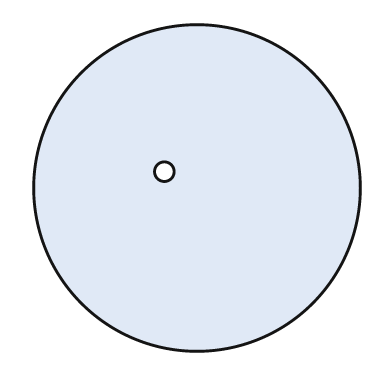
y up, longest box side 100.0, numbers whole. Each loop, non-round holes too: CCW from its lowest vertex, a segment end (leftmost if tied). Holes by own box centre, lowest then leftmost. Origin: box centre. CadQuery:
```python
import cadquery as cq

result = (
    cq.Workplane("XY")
    .moveTo(0.0, 0.0)
    .circle(50.0)
    .moveTo(-10.0, 5.0)
    .circle(3.0)
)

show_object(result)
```